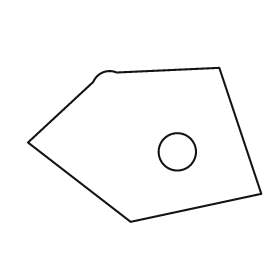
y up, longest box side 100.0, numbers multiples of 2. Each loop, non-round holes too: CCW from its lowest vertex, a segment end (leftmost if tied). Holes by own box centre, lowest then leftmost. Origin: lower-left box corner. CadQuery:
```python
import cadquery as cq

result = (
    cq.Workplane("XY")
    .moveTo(44.0, 0.0)
    .lineTo(100.0, 12.0)
    .lineTo(82.0, 66.0)
    .lineTo(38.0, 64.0)
    .threePointArc((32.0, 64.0), (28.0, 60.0))
    .lineTo(0.0, 34.0)
    .close()
    .moveTo(64.0, 30.0)
    .circle(8.0)
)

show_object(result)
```